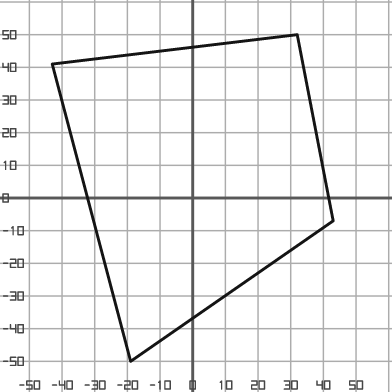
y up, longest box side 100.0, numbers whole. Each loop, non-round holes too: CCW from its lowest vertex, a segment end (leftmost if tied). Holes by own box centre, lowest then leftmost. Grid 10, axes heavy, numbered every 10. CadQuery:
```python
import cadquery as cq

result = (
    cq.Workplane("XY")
    .moveTo(-19.0, -50.0)
    .lineTo(43.0, -7.0)
    .lineTo(32.0, 50.0)
    .lineTo(-43.0, 41.0)
    .close()
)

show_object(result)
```